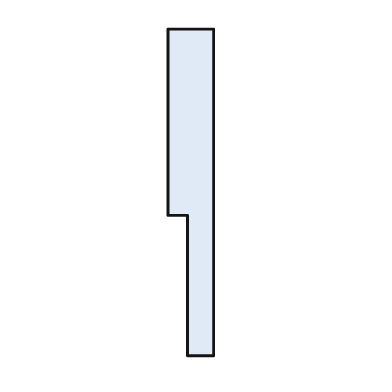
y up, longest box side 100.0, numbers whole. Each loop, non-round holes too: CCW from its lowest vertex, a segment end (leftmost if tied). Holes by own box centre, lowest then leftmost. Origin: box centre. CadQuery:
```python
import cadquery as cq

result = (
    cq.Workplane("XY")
    .moveTo(-1.0, -50.0)
    .lineTo(7.0, -50.0)
    .lineTo(7.0, 50.0)
    .lineTo(-7.0, 50.0)
    .lineTo(-7.0, -7.0)
    .lineTo(-1.0, -7.0)
    .close()
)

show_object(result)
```